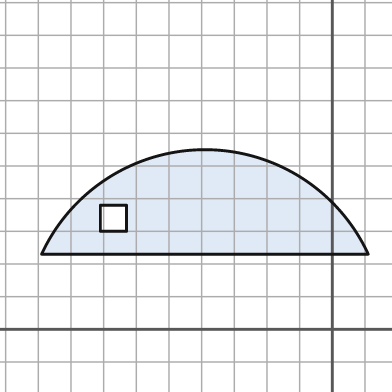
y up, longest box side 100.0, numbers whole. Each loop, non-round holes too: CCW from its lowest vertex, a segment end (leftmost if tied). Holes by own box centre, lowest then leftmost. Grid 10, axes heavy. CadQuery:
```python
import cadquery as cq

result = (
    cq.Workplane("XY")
    .moveTo(-89.0, 23.0)
    .lineTo(11.0, 23.0)
    .threePointArc((-39.0, 55.0), (-89.0, 23.0))
    .close()
    .moveTo(-71.0, 30.0)
    .lineTo(-63.0, 30.0)
    .lineTo(-63.0, 38.0)
    .lineTo(-71.0, 38.0)
    .close()
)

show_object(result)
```